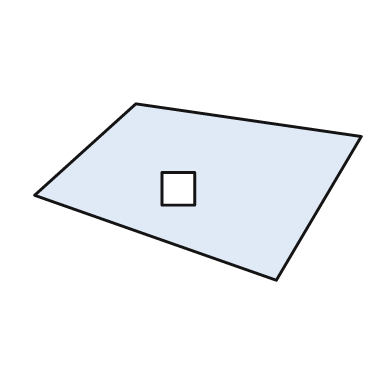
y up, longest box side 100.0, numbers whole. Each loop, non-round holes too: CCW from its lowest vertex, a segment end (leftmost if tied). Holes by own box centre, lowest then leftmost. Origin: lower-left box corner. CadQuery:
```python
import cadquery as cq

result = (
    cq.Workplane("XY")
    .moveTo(74.0, 0.0)
    .lineTo(100.0, 44.0)
    .lineTo(31.0, 54.0)
    .lineTo(0.0, 26.0)
    .close()
    .moveTo(39.0, 23.0)
    .lineTo(49.0, 23.0)
    .lineTo(49.0, 33.0)
    .lineTo(39.0, 33.0)
    .close()
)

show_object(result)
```